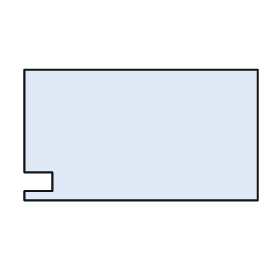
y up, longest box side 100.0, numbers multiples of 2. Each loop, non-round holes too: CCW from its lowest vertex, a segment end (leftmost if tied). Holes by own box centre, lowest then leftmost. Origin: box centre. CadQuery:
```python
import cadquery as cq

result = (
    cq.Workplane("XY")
    .moveTo(-50.0, -28.0)
    .lineTo(50.0, -28.0)
    .lineTo(50.0, 28.0)
    .lineTo(-50.0, 28.0)
    .lineTo(-50.0, -16.0)
    .lineTo(-38.0, -16.0)
    .lineTo(-38.0, -24.0)
    .lineTo(-50.0, -24.0)
    .close()
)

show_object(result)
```